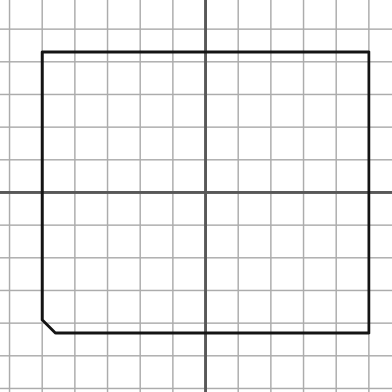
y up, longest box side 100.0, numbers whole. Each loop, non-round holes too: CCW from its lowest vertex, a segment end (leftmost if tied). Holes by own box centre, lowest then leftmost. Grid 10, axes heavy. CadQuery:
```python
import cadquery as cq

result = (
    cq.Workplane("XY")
    .moveTo(-46.0, -43.0)
    .lineTo(50.0, -43.0)
    .lineTo(50.0, 43.0)
    .lineTo(-50.0, 43.0)
    .lineTo(-50.0, -39.0)
    .close()
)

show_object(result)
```